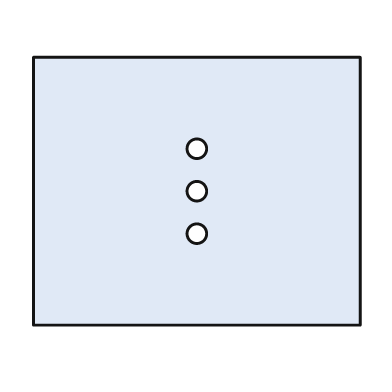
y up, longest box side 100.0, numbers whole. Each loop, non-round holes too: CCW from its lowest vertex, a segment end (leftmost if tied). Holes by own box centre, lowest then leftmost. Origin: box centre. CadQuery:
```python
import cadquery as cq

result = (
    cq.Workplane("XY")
    .moveTo(-50.0, -41.0)
    .lineTo(50.0, -41.0)
    .lineTo(50.0, 41.0)
    .lineTo(-50.0, 41.0)
    .close()
    .moveTo(0.0, -13.0)
    .circle(3.0)
    .moveTo(0.0, 0.0)
    .circle(3.0)
    .moveTo(0.0, 13.0)
    .circle(3.0)
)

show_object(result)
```